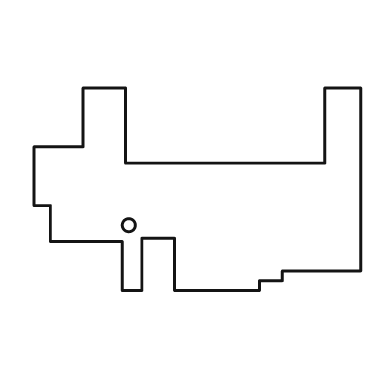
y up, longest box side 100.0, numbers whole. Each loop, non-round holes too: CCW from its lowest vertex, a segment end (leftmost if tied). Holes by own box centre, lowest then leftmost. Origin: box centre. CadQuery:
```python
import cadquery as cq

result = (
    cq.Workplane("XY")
    .moveTo(-23.0, -31.0)
    .lineTo(-17.0, -31.0)
    .lineTo(-17.0, -15.0)
    .lineTo(-7.0, -15.0)
    .lineTo(-7.0, -31.0)
    .lineTo(19.0, -31.0)
    .lineTo(19.0, -28.0)
    .lineTo(26.0, -28.0)
    .lineTo(26.0, -25.0)
    .lineTo(50.0, -25.0)
    .lineTo(50.0, 31.0)
    .lineTo(39.0, 31.0)
    .lineTo(39.0, 8.0)
    .lineTo(-22.0, 8.0)
    .lineTo(-22.0, 31.0)
    .lineTo(-35.0, 31.0)
    .lineTo(-35.0, 13.0)
    .lineTo(-50.0, 13.0)
    .lineTo(-50.0, -5.0)
    .lineTo(-45.0, -5.0)
    .lineTo(-45.0, -16.0)
    .lineTo(-23.0, -16.0)
    .close()
    .moveTo(-21.0, -11.0)
    .circle(2.0)
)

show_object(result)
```